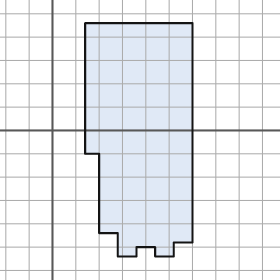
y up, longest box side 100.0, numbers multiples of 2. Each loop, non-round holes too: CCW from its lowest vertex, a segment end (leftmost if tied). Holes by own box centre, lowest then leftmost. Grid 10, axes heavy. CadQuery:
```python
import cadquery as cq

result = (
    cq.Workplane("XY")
    .moveTo(28.0, -54.0)
    .lineTo(36.0, -54.0)
    .lineTo(36.0, -50.0)
    .lineTo(44.0, -50.0)
    .lineTo(44.0, -54.0)
    .lineTo(52.0, -54.0)
    .lineTo(52.0, -48.0)
    .lineTo(60.0, -48.0)
    .lineTo(60.0, 46.0)
    .lineTo(14.0, 46.0)
    .lineTo(14.0, -10.0)
    .lineTo(20.0, -10.0)
    .lineTo(20.0, -44.0)
    .lineTo(28.0, -44.0)
    .close()
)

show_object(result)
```